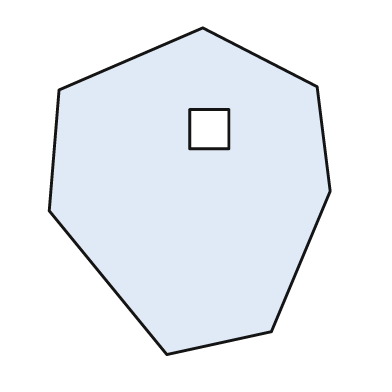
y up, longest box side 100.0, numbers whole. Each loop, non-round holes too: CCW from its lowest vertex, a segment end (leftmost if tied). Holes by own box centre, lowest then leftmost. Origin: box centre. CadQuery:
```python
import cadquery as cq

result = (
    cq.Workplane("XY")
    .moveTo(-7.0, -50.0)
    .lineTo(25.0, -43.0)
    .lineTo(43.0, 0.0)
    .lineTo(39.0, 32.0)
    .lineTo(4.0, 50.0)
    .lineTo(-40.0, 31.0)
    .lineTo(-43.0, -6.0)
    .close()
    .moveTo(0.0, 13.0)
    .lineTo(12.0, 13.0)
    .lineTo(12.0, 25.0)
    .lineTo(0.0, 25.0)
    .close()
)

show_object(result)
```